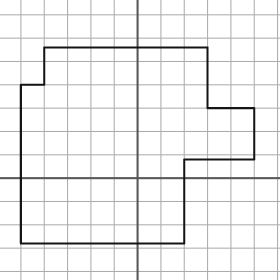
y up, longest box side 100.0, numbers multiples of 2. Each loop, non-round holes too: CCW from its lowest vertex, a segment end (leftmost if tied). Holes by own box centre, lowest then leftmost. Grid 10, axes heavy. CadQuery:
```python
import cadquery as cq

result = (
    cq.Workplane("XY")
    .moveTo(-50.0, -28.0)
    .lineTo(20.0, -28.0)
    .lineTo(20.0, 8.0)
    .lineTo(50.0, 8.0)
    .lineTo(50.0, 30.0)
    .lineTo(30.0, 30.0)
    .lineTo(30.0, 56.0)
    .lineTo(-40.0, 56.0)
    .lineTo(-40.0, 40.0)
    .lineTo(-50.0, 40.0)
    .close()
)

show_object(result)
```